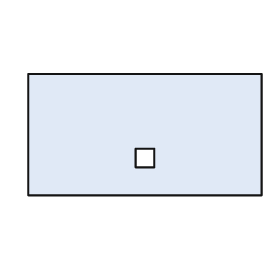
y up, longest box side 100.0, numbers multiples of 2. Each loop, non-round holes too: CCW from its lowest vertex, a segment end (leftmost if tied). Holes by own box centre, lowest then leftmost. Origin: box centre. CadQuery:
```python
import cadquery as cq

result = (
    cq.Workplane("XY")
    .moveTo(-50.0, -26.0)
    .lineTo(50.0, -26.0)
    .lineTo(50.0, 26.0)
    .lineTo(-50.0, 26.0)
    .close()
    .moveTo(-4.0, -14.0)
    .lineTo(4.0, -14.0)
    .lineTo(4.0, -6.0)
    .lineTo(-4.0, -6.0)
    .close()
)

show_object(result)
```